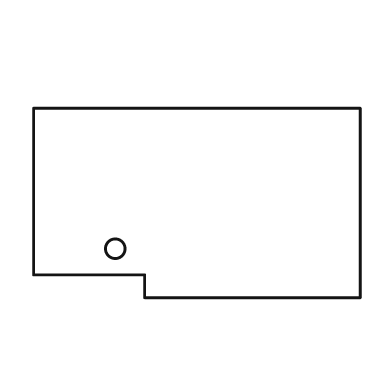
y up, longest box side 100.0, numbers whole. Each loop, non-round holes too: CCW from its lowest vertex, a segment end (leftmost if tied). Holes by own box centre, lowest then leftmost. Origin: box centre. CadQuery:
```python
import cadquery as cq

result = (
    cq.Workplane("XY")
    .moveTo(-16.0, -29.0)
    .lineTo(50.0, -29.0)
    .lineTo(50.0, 29.0)
    .lineTo(-50.0, 29.0)
    .lineTo(-50.0, -22.0)
    .lineTo(-16.0, -22.0)
    .close()
    .moveTo(-25.0, -14.0)
    .circle(3.0)
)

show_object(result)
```